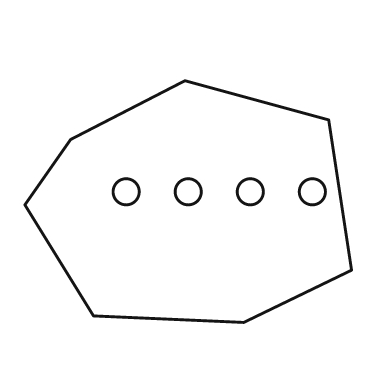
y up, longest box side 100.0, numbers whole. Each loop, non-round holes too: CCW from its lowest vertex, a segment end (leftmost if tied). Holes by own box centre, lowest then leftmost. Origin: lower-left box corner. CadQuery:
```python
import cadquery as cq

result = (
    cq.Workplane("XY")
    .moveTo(67.0, 0.0)
    .lineTo(100.0, 16.0)
    .lineTo(93.0, 62.0)
    .lineTo(49.0, 74.0)
    .lineTo(14.0, 56.0)
    .lineTo(0.0, 36.0)
    .lineTo(21.0, 2.0)
    .close()
    .moveTo(31.0, 40.0)
    .circle(4.0)
    .moveTo(50.0, 40.0)
    .circle(4.0)
    .moveTo(69.0, 40.0)
    .circle(4.0)
    .moveTo(88.0, 40.0)
    .circle(4.0)
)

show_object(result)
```